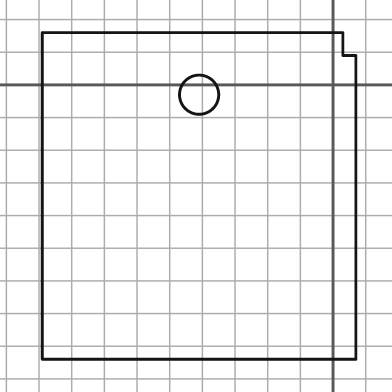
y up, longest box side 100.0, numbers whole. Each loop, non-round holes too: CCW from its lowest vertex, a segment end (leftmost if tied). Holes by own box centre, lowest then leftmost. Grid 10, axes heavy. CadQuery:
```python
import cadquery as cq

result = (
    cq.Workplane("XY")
    .moveTo(-89.0, -84.0)
    .lineTo(7.0, -84.0)
    .lineTo(7.0, 9.0)
    .lineTo(3.0, 9.0)
    .lineTo(3.0, 16.0)
    .lineTo(-89.0, 16.0)
    .close()
    .moveTo(-41.0, -3.0)
    .circle(6.0)
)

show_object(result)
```